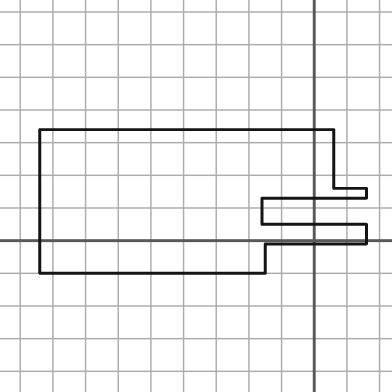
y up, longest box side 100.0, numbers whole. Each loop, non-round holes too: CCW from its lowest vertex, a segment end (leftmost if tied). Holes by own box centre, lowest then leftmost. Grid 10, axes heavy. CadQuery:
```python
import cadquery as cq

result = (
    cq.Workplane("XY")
    .moveTo(-84.0, -10.0)
    .lineTo(-15.0, -10.0)
    .lineTo(-15.0, -1.0)
    .lineTo(16.0, -1.0)
    .lineTo(16.0, 5.0)
    .lineTo(-16.0, 5.0)
    .lineTo(-16.0, 13.0)
    .lineTo(16.0, 13.0)
    .lineTo(16.0, 16.0)
    .lineTo(6.0, 16.0)
    .lineTo(6.0, 34.0)
    .lineTo(-84.0, 34.0)
    .close()
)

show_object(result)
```